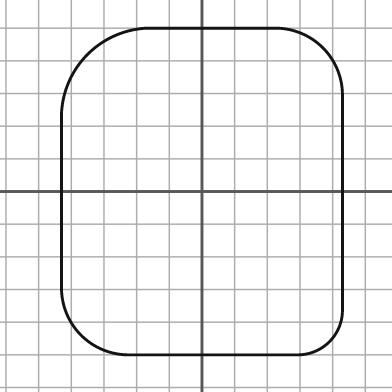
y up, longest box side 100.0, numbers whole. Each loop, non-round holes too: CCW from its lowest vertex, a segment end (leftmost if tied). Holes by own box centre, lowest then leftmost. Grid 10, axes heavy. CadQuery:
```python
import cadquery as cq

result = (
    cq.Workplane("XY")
    .moveTo(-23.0, -50.0)
    .lineTo(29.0, -50.0)
    .threePointArc((39.0, -46.0), (43.0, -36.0))
    .lineTo(43.0, 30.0)
    .threePointArc((37.0, 44.0), (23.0, 50.0))
    .lineTo(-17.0, 50.0)
    .threePointArc((-35.0, 42.0), (-43.0, 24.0))
    .lineTo(-43.0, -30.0)
    .threePointArc((-37.0, -44.0), (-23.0, -50.0))
    .close()
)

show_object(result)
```